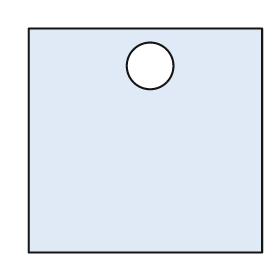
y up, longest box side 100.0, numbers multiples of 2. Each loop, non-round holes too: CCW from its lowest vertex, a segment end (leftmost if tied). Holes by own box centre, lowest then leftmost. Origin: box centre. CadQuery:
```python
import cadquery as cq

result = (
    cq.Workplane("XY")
    .moveTo(-50.0, -48.0)
    .lineTo(50.0, -48.0)
    .lineTo(50.0, 48.0)
    .lineTo(-50.0, 48.0)
    .close()
    .moveTo(2.0, 32.0)
    .circle(10.0)
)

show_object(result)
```